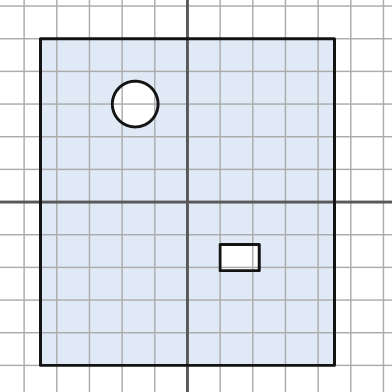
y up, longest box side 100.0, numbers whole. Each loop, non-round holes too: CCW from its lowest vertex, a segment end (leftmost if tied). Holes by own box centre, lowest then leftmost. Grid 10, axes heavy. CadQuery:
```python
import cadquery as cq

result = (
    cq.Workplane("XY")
    .moveTo(-45.0, -50.0)
    .lineTo(45.0, -50.0)
    .lineTo(45.0, 50.0)
    .lineTo(-45.0, 50.0)
    .close()
    .moveTo(10.0, -21.0)
    .lineTo(22.0, -21.0)
    .lineTo(22.0, -13.0)
    .lineTo(10.0, -13.0)
    .close()
    .moveTo(-16.0, 30.0)
    .circle(7.0)
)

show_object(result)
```